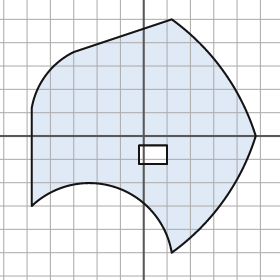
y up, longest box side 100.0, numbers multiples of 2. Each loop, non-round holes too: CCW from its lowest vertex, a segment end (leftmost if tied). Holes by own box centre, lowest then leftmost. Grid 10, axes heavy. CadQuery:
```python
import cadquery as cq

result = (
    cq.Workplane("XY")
    .moveTo(12.0, -50.0)
    .threePointArc((34.0, -28.0), (48.0, 0.0))
    .threePointArc((34.0, 28.0), (12.0, 50.0))
    .lineTo(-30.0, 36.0)
    .threePointArc((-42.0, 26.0), (-48.0, 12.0))
    .lineTo(-48.0, -30.0)
    .threePointArc((-12.0, -22.0), (12.0, -50.0))
    .close()
    .moveTo(-2.0, -12.0)
    .lineTo(10.0, -12.0)
    .lineTo(10.0, -4.0)
    .lineTo(-2.0, -4.0)
    .close()
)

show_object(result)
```